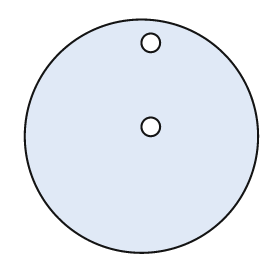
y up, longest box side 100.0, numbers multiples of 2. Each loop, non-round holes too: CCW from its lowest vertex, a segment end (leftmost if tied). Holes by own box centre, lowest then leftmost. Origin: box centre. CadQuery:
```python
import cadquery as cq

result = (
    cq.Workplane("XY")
    .moveTo(0.0, 0.0)
    .circle(50.0)
    .moveTo(4.0, 4.0)
    .circle(4.0)
    .moveTo(4.0, 40.0)
    .circle(4.0)
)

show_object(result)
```